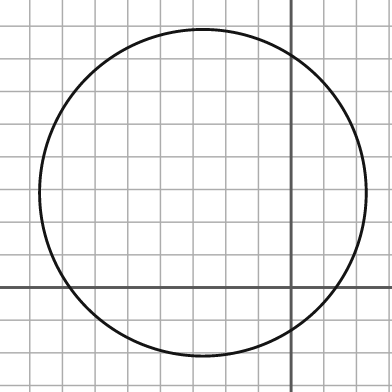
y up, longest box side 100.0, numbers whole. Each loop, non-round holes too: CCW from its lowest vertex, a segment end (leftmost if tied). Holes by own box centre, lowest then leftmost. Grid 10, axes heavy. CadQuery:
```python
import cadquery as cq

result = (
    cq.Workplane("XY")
    .moveTo(-27.0, 29.0)
    .circle(50.0)
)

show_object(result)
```